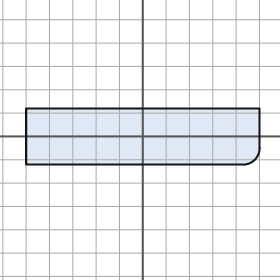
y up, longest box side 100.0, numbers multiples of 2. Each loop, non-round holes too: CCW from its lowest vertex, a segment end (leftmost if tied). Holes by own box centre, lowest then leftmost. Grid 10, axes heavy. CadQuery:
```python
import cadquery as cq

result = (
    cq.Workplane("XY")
    .moveTo(-50.0, -12.0)
    .lineTo(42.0, -12.0)
    .threePointArc((48.0, -10.0), (50.0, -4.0))
    .lineTo(50.0, 12.0)
    .lineTo(-50.0, 12.0)
    .close()
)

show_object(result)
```